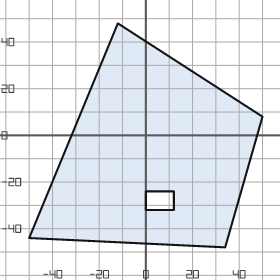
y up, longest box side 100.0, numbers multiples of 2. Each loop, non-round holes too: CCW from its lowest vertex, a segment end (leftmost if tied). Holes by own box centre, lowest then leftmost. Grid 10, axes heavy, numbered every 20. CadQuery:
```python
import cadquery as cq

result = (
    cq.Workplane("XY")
    .moveTo(34.0, -48.0)
    .lineTo(50.0, 8.0)
    .lineTo(-12.0, 48.0)
    .lineTo(-50.0, -44.0)
    .close()
    .moveTo(0.0, -32.0)
    .lineTo(12.0, -32.0)
    .lineTo(12.0, -24.0)
    .lineTo(0.0, -24.0)
    .close()
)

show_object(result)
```